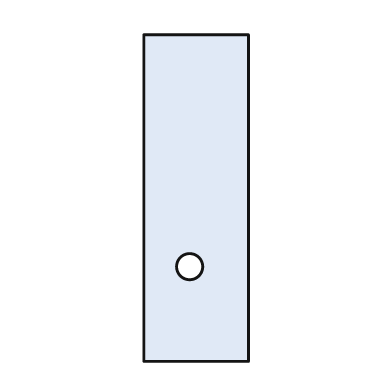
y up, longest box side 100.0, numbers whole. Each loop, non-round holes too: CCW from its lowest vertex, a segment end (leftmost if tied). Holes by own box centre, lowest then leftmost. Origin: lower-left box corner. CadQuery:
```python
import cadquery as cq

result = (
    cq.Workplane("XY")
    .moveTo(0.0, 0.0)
    .lineTo(32.0, 0.0)
    .lineTo(32.0, 100.0)
    .lineTo(0.0, 100.0)
    .close()
    .moveTo(14.0, 29.0)
    .circle(4.0)
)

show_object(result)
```